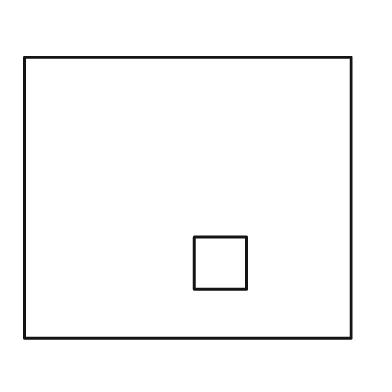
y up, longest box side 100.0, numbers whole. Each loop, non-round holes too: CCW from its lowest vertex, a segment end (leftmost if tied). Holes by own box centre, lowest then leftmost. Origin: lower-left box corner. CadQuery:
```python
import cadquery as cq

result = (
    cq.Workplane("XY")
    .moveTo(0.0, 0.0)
    .lineTo(100.0, 0.0)
    .lineTo(100.0, 86.0)
    .lineTo(0.0, 86.0)
    .close()
    .moveTo(52.0, 15.0)
    .lineTo(68.0, 15.0)
    .lineTo(68.0, 31.0)
    .lineTo(52.0, 31.0)
    .close()
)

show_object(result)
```